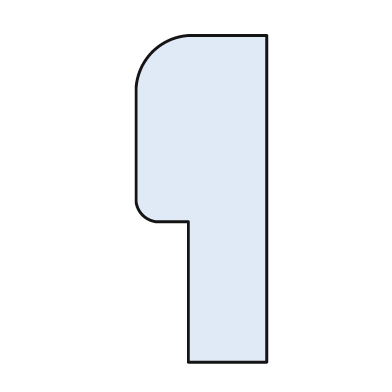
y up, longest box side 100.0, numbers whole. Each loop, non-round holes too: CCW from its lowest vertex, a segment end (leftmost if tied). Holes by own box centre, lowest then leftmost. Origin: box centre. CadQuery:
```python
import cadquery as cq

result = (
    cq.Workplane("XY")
    .moveTo(-4.0, -50.0)
    .lineTo(20.0, -50.0)
    .lineTo(20.0, 50.0)
    .lineTo(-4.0, 50.0)
    .threePointArc((-15.0, 45.0), (-20.0, 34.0))
    .lineTo(-20.0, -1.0)
    .threePointArc((-18.0, -5.0), (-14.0, -7.0))
    .lineTo(-4.0, -7.0)
    .close()
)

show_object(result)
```